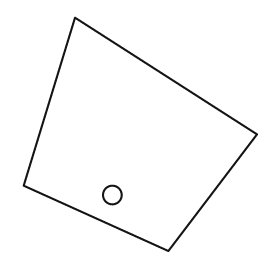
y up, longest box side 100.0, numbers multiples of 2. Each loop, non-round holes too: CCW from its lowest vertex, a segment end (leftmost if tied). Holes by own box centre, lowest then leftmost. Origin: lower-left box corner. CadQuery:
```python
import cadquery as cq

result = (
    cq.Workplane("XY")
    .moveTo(62.0, 0.0)
    .lineTo(100.0, 50.0)
    .lineTo(22.0, 100.0)
    .lineTo(0.0, 28.0)
    .close()
    .moveTo(38.0, 24.0)
    .circle(4.0)
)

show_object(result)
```